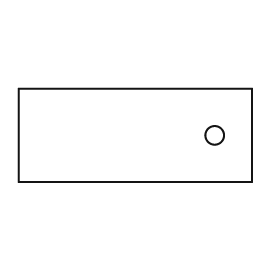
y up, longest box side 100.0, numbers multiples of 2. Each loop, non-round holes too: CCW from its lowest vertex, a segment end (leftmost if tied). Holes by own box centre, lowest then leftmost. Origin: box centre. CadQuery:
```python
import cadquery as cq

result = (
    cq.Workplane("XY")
    .moveTo(-50.0, -20.0)
    .lineTo(50.0, -20.0)
    .lineTo(50.0, 20.0)
    .lineTo(-50.0, 20.0)
    .close()
    .moveTo(34.0, 0.0)
    .circle(4.0)
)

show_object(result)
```